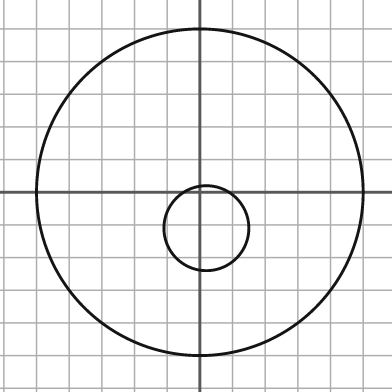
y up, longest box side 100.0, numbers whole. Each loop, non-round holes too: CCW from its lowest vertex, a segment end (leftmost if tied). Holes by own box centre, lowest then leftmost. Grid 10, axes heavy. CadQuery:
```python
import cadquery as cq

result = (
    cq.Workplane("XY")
    .moveTo(0.0, 0.0)
    .circle(50.0)
    .moveTo(2.0, -11.0)
    .circle(13.0)
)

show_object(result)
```